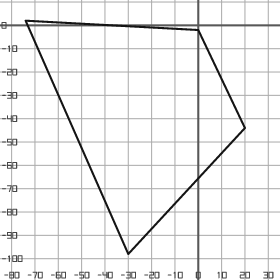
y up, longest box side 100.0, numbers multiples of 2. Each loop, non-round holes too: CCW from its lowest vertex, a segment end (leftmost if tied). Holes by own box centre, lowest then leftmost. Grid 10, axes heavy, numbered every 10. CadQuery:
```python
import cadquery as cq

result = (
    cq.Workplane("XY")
    .moveTo(-30.0, -98.0)
    .lineTo(20.0, -44.0)
    .lineTo(0.0, -2.0)
    .lineTo(-74.0, 2.0)
    .close()
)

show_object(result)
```